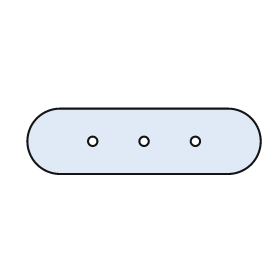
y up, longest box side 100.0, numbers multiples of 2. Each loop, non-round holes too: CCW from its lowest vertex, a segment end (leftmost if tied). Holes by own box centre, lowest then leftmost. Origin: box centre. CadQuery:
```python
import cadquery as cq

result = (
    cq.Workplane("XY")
    .moveTo(-36.0, -14.0)
    .lineTo(36.0, -14.0)
    .threePointArc((50.0, 0.0), (36.0, 14.0))
    .lineTo(-36.0, 14.0)
    .threePointArc((-50.0, 0.0), (-36.0, -14.0))
    .close()
    .moveTo(-22.0, 0.0)
    .circle(2.0)
    .moveTo(0.0, 0.0)
    .circle(2.0)
    .moveTo(22.0, 0.0)
    .circle(2.0)
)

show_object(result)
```